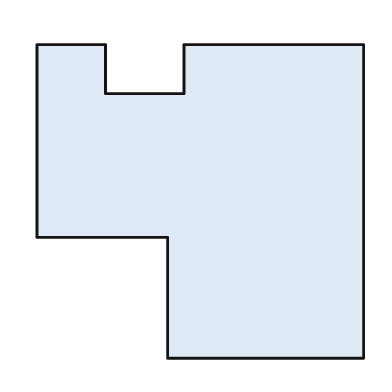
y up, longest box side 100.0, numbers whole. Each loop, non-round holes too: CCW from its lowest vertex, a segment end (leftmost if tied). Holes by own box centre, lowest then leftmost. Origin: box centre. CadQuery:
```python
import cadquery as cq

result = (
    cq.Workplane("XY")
    .moveTo(-10.0, -48.0)
    .lineTo(50.0, -48.0)
    .lineTo(50.0, 48.0)
    .lineTo(-5.0, 48.0)
    .lineTo(-5.0, 33.0)
    .lineTo(-29.0, 33.0)
    .lineTo(-29.0, 48.0)
    .lineTo(-50.0, 48.0)
    .lineTo(-50.0, -11.0)
    .lineTo(-10.0, -11.0)
    .close()
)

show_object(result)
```